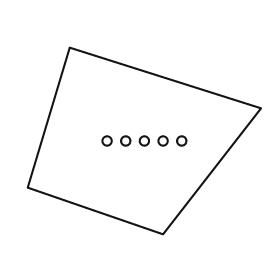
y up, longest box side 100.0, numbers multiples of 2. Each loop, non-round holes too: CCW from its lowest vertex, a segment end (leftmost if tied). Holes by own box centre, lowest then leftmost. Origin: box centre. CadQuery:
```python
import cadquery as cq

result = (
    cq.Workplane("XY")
    .moveTo(8.0, -40.0)
    .lineTo(50.0, 14.0)
    .lineTo(-32.0, 40.0)
    .lineTo(-50.0, -20.0)
    .close()
    .moveTo(-16.0, 0.0)
    .circle(2.0)
    .moveTo(-8.0, 0.0)
    .circle(2.0)
    .moveTo(0.0, 0.0)
    .circle(2.0)
    .moveTo(8.0, 0.0)
    .circle(2.0)
    .moveTo(16.0, 0.0)
    .circle(2.0)
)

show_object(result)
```